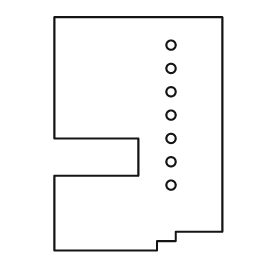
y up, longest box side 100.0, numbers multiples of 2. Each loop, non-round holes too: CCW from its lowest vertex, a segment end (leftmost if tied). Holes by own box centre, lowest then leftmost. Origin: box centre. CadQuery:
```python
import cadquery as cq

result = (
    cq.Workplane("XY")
    .moveTo(-36.0, -50.0)
    .lineTo(8.0, -50.0)
    .lineTo(8.0, -46.0)
    .lineTo(16.0, -46.0)
    .lineTo(16.0, -42.0)
    .lineTo(36.0, -42.0)
    .lineTo(36.0, 50.0)
    .lineTo(-36.0, 50.0)
    .lineTo(-36.0, -2.0)
    .lineTo(0.0, -2.0)
    .lineTo(0.0, -18.0)
    .lineTo(-36.0, -18.0)
    .close()
    .moveTo(14.0, -22.0)
    .circle(2.0)
    .moveTo(14.0, -12.0)
    .circle(2.0)
    .moveTo(14.0, -2.0)
    .circle(2.0)
    .moveTo(14.0, 8.0)
    .circle(2.0)
    .moveTo(14.0, 18.0)
    .circle(2.0)
    .moveTo(14.0, 28.0)
    .circle(2.0)
    .moveTo(14.0, 38.0)
    .circle(2.0)
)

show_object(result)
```